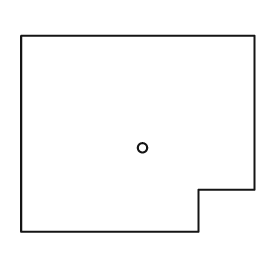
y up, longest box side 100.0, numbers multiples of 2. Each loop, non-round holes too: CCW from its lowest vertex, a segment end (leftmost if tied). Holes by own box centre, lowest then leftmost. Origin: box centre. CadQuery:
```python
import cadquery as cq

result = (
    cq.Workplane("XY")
    .moveTo(-50.0, -42.0)
    .lineTo(26.0, -42.0)
    .lineTo(26.0, -24.0)
    .lineTo(50.0, -24.0)
    .lineTo(50.0, 42.0)
    .lineTo(-50.0, 42.0)
    .close()
    .moveTo(2.0, -6.0)
    .circle(2.0)
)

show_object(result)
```